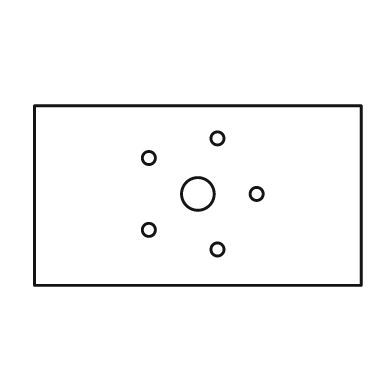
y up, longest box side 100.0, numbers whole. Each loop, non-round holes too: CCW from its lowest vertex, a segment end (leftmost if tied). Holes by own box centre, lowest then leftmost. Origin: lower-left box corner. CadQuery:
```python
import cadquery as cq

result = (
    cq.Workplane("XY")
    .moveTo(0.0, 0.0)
    .lineTo(100.0, 0.0)
    .lineTo(100.0, 55.0)
    .lineTo(0.0, 55.0)
    .close()
    .moveTo(56.0, 11.0)
    .circle(2.0)
    .moveTo(35.0, 17.0)
    .circle(2.0)
    .moveTo(50.0, 28.0)
    .circle(5.0)
    .moveTo(68.0, 28.0)
    .circle(2.0)
    .moveTo(35.0, 39.0)
    .circle(2.0)
    .moveTo(56.0, 45.0)
    .circle(2.0)
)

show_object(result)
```